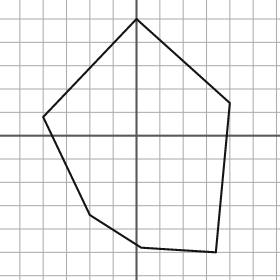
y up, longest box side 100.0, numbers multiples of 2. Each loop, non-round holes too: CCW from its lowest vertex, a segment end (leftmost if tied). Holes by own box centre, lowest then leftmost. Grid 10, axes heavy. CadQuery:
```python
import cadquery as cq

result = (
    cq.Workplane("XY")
    .moveTo(34.0, -50.0)
    .lineTo(40.0, 14.0)
    .lineTo(0.0, 50.0)
    .lineTo(-40.0, 8.0)
    .lineTo(-20.0, -34.0)
    .lineTo(2.0, -48.0)
    .close()
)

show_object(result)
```